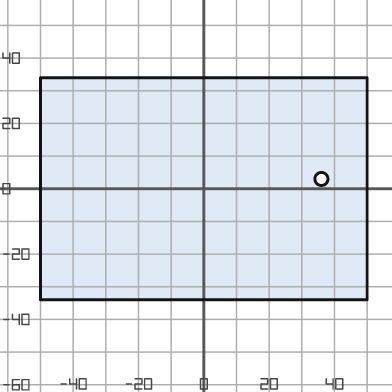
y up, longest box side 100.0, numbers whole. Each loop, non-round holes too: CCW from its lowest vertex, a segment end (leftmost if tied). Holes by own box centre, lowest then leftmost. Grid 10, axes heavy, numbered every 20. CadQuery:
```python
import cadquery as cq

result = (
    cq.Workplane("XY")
    .moveTo(-50.0, -34.0)
    .lineTo(50.0, -34.0)
    .lineTo(50.0, 34.0)
    .lineTo(-50.0, 34.0)
    .close()
    .moveTo(36.0, 3.0)
    .circle(2.0)
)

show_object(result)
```